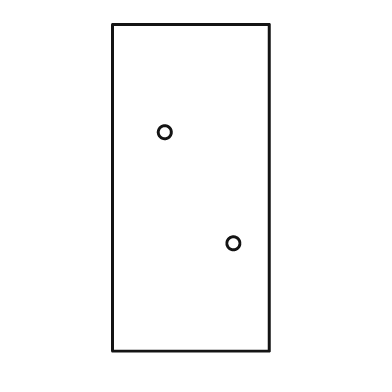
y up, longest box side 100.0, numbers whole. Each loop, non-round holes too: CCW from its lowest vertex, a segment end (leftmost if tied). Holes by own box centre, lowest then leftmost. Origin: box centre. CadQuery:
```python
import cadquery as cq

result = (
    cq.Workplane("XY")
    .moveTo(-24.0, -50.0)
    .lineTo(24.0, -50.0)
    .lineTo(24.0, 50.0)
    .lineTo(-24.0, 50.0)
    .close()
    .moveTo(13.0, -17.0)
    .circle(2.0)
    .moveTo(-8.0, 17.0)
    .circle(2.0)
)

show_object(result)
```